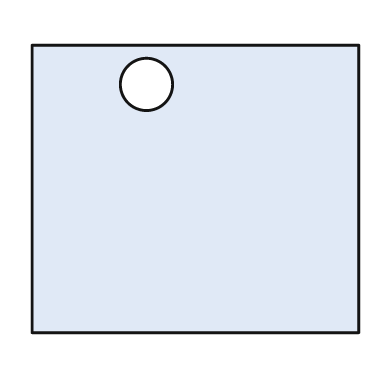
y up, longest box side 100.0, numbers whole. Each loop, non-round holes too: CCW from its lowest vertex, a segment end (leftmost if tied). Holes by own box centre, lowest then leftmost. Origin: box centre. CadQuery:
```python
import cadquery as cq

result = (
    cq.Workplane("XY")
    .moveTo(-50.0, -44.0)
    .lineTo(50.0, -44.0)
    .lineTo(50.0, 44.0)
    .lineTo(-50.0, 44.0)
    .close()
    .moveTo(-15.0, 32.0)
    .circle(8.0)
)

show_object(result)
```